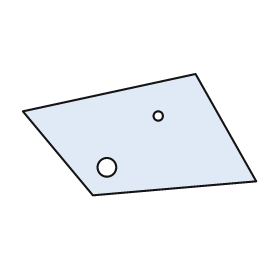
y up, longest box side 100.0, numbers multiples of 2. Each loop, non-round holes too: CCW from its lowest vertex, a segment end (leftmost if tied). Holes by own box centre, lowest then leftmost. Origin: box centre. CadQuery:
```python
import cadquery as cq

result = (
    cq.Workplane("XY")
    .moveTo(-20.0, -26.0)
    .lineTo(50.0, -20.0)
    .lineTo(24.0, 26.0)
    .lineTo(-50.0, 10.0)
    .close()
    .moveTo(-14.0, -14.0)
    .circle(4.0)
    .moveTo(8.0, 8.0)
    .circle(2.0)
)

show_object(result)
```